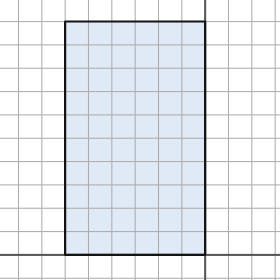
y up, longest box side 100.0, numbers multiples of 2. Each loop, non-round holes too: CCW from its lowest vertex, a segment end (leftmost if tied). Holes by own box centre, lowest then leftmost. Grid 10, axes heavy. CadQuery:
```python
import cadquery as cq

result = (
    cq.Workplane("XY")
    .moveTo(-60.0, 0.0)
    .lineTo(0.0, 0.0)
    .lineTo(0.0, 100.0)
    .lineTo(-60.0, 100.0)
    .close()
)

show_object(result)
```